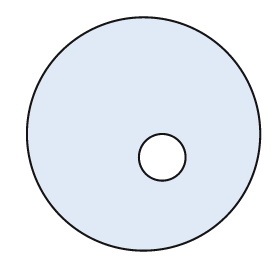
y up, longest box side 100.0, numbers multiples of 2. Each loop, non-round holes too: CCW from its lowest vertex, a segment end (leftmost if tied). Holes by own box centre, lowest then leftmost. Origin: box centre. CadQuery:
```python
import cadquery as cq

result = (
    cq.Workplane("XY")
    .moveTo(0.0, 0.0)
    .circle(50.0)
    .moveTo(8.0, -10.0)
    .circle(10.0)
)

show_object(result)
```